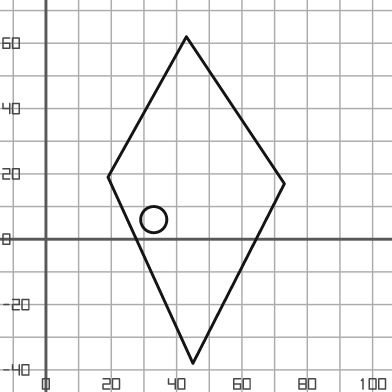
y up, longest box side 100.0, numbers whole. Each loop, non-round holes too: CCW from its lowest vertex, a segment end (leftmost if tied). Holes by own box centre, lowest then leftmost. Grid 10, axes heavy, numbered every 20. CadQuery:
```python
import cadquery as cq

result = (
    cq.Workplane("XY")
    .moveTo(45.0, -38.0)
    .lineTo(73.0, 17.0)
    .lineTo(43.0, 62.0)
    .lineTo(19.0, 19.0)
    .close()
    .moveTo(33.0, 6.0)
    .circle(4.0)
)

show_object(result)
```